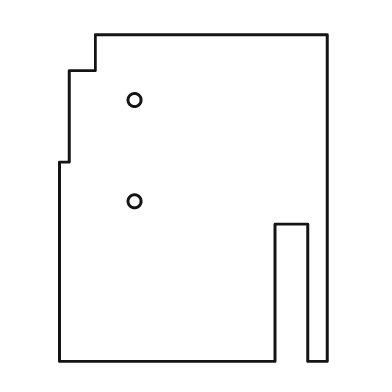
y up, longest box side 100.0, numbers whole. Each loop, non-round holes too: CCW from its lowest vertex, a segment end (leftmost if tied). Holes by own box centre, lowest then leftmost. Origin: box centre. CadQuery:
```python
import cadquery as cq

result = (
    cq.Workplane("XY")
    .moveTo(-41.0, -50.0)
    .lineTo(25.0, -50.0)
    .lineTo(25.0, -8.0)
    .lineTo(35.0, -8.0)
    .lineTo(35.0, -50.0)
    .lineTo(41.0, -50.0)
    .lineTo(41.0, 50.0)
    .lineTo(-30.0, 50.0)
    .lineTo(-30.0, 39.0)
    .lineTo(-38.0, 39.0)
    .lineTo(-38.0, 11.0)
    .lineTo(-41.0, 11.0)
    .close()
    .moveTo(-18.0, -1.0)
    .circle(2.0)
    .moveTo(-18.0, 30.0)
    .circle(2.0)
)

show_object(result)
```